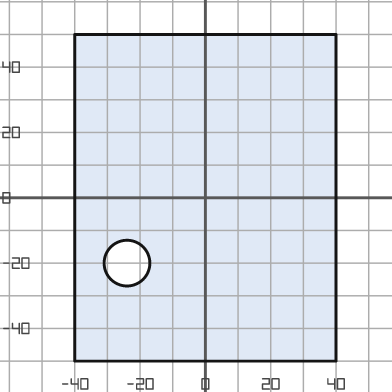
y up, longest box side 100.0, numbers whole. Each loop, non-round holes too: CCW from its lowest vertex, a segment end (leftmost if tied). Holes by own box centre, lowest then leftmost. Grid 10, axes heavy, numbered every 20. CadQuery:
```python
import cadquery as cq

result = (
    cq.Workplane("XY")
    .moveTo(-40.0, -50.0)
    .lineTo(40.0, -50.0)
    .lineTo(40.0, 50.0)
    .lineTo(-40.0, 50.0)
    .close()
    .moveTo(-24.0, -20.0)
    .circle(7.0)
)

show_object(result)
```